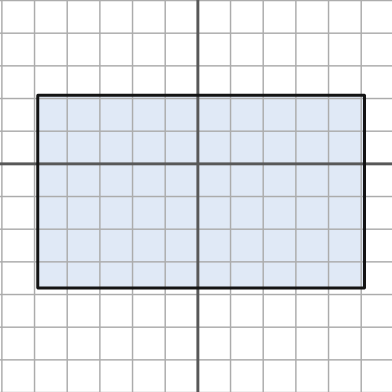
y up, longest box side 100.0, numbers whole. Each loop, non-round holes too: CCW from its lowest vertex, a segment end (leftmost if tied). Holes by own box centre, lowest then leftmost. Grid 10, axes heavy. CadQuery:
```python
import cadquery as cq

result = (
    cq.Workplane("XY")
    .moveTo(-49.0, -38.0)
    .lineTo(51.0, -38.0)
    .lineTo(51.0, 21.0)
    .lineTo(-49.0, 21.0)
    .close()
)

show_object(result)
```